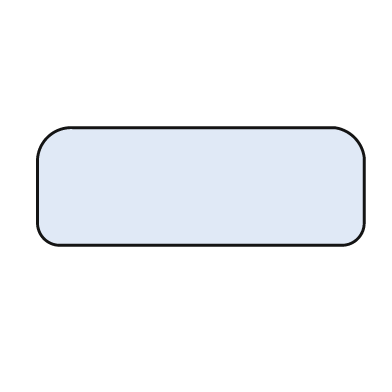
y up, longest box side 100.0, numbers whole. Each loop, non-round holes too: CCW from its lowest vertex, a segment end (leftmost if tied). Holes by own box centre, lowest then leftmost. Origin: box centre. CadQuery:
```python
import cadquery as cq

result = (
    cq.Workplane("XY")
    .moveTo(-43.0, -18.0)
    .lineTo(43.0, -18.0)
    .threePointArc((48.0, -16.0), (50.0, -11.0))
    .lineTo(50.0, 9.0)
    .threePointArc((47.0, 15.0), (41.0, 18.0))
    .lineTo(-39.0, 18.0)
    .threePointArc((-47.0, 15.0), (-50.0, 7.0))
    .lineTo(-50.0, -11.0)
    .threePointArc((-48.0, -16.0), (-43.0, -18.0))
    .close()
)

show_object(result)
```